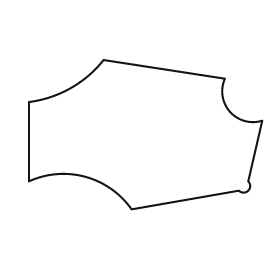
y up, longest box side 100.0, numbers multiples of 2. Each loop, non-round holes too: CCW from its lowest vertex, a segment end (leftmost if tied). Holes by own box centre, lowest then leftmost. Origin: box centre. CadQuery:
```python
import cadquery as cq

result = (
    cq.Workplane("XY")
    .moveTo(-6.0, -32.0)
    .lineTo(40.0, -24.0)
    .threePointArc((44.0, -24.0), (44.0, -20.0))
    .lineTo(50.0, 6.0)
    .threePointArc((36.0, 10.0), (34.0, 24.0))
    .lineTo(-18.0, 32.0)
    .threePointArc((-32.0, 20.0), (-50.0, 14.0))
    .lineTo(-50.0, -20.0)
    .threePointArc((-26.0, -18.0), (-6.0, -32.0))
    .close()
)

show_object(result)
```